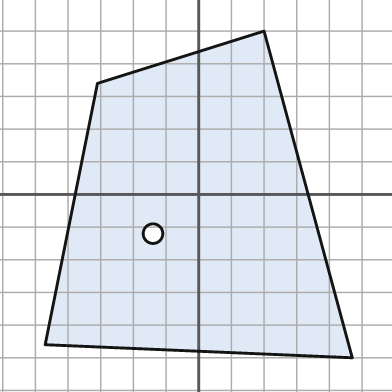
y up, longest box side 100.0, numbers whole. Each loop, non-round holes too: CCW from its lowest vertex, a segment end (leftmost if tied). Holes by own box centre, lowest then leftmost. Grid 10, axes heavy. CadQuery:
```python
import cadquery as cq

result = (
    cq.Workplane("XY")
    .moveTo(47.0, -50.0)
    .lineTo(20.0, 50.0)
    .lineTo(-31.0, 34.0)
    .lineTo(-47.0, -46.0)
    .close()
    .moveTo(-14.0, -12.0)
    .circle(3.0)
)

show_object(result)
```